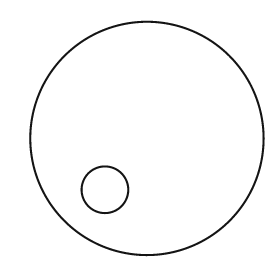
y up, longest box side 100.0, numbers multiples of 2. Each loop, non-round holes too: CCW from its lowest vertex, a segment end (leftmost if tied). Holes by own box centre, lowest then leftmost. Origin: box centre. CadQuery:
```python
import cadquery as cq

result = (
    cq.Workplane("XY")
    .moveTo(0.0, 0.0)
    .circle(50.0)
    .moveTo(-18.0, -22.0)
    .circle(10.0)
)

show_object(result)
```